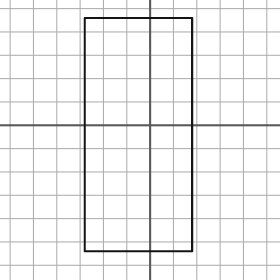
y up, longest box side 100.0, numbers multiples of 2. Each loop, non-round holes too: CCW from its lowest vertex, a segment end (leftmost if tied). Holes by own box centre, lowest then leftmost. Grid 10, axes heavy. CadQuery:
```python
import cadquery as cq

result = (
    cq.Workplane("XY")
    .moveTo(-28.0, -54.0)
    .lineTo(18.0, -54.0)
    .lineTo(18.0, 46.0)
    .lineTo(-28.0, 46.0)
    .close()
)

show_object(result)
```